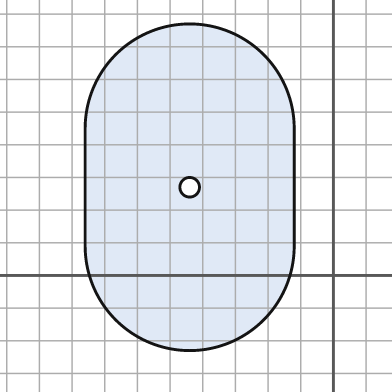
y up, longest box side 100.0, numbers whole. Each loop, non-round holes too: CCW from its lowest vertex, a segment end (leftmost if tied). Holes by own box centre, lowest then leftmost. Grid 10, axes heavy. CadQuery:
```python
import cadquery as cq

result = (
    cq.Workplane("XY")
    .moveTo(-76.0, 9.0)
    .threePointArc((-44.0, -23.0), (-12.0, 9.0))
    .lineTo(-12.0, 45.0)
    .threePointArc((-44.0, 77.0), (-76.0, 45.0))
    .close()
    .moveTo(-44.0, 27.0)
    .circle(3.0)
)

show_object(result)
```